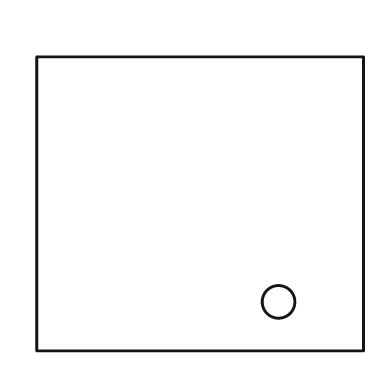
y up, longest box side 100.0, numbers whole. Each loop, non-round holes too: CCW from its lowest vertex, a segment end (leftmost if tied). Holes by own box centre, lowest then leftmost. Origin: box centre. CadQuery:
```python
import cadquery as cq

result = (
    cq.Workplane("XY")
    .moveTo(-50.0, -45.0)
    .lineTo(50.0, -45.0)
    .lineTo(50.0, 45.0)
    .lineTo(-50.0, 45.0)
    .close()
    .moveTo(24.0, -30.0)
    .circle(5.0)
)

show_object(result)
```